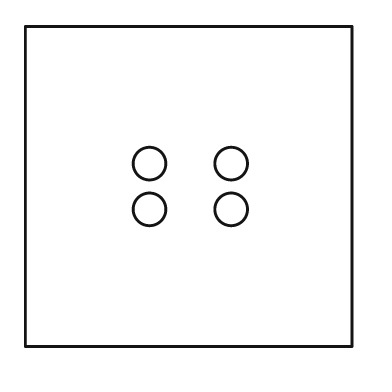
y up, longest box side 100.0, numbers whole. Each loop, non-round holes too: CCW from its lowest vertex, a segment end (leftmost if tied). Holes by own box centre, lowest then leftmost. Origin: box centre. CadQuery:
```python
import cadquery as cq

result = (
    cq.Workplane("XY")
    .moveTo(-50.0, -49.0)
    .lineTo(50.0, -49.0)
    .lineTo(50.0, 49.0)
    .lineTo(-50.0, 49.0)
    .close()
    .moveTo(-12.0, -7.0)
    .circle(5.0)
    .moveTo(13.0, -7.0)
    .circle(5.0)
    .moveTo(-12.0, 7.0)
    .circle(5.0)
    .moveTo(13.0, 7.0)
    .circle(5.0)
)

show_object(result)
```